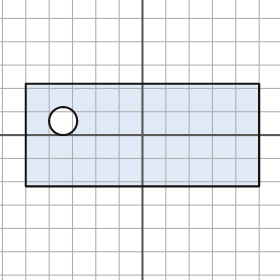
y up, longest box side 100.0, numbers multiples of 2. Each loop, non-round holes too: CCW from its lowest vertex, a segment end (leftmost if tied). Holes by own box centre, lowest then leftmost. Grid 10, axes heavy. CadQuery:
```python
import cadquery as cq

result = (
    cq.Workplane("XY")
    .moveTo(-50.0, -22.0)
    .lineTo(50.0, -22.0)
    .lineTo(50.0, 22.0)
    .lineTo(-50.0, 22.0)
    .close()
    .moveTo(-34.0, 6.0)
    .circle(6.0)
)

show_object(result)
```